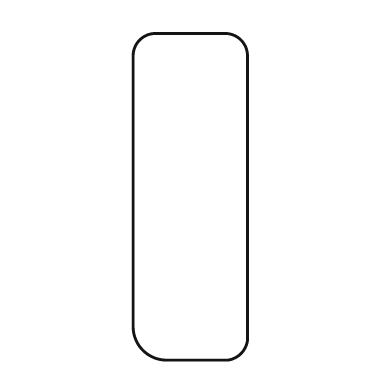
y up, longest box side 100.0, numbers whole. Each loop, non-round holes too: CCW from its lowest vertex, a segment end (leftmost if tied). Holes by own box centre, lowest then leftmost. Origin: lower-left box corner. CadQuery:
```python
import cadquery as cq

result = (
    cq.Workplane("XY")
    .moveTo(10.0, 0.0)
    .lineTo(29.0, 0.0)
    .threePointArc((33.0, 2.0), (35.0, 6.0))
    .lineTo(35.0, 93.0)
    .threePointArc((33.0, 98.0), (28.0, 100.0))
    .lineTo(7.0, 100.0)
    .threePointArc((2.0, 98.0), (0.0, 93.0))
    .lineTo(0.0, 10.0)
    .threePointArc((3.0, 3.0), (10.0, 0.0))
    .close()
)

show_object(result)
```